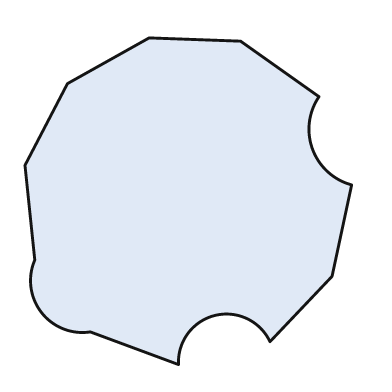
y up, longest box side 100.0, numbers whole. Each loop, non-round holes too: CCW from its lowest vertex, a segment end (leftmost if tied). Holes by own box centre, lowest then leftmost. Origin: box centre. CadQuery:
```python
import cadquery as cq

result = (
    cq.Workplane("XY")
    .moveTo(-3.0, -50.0)
    .threePointArc((8.0, -35.0), (25.0, -43.0))
    .lineTo(44.0, -23.0)
    .lineTo(50.0, 5.0)
    .threePointArc((38.0, 16.0), (40.0, 32.0))
    .lineTo(16.0, 49.0)
    .lineTo(-12.0, 50.0)
    .lineTo(-37.0, 36.0)
    .lineTo(-50.0, 11.0)
    .lineTo(-47.0, -18.0)
    .threePointArc((-45.0, -34.0), (-30.0, -40.0))
    .close()
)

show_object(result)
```